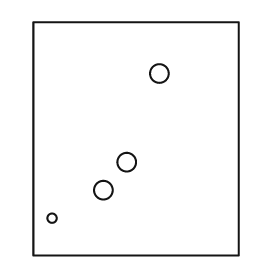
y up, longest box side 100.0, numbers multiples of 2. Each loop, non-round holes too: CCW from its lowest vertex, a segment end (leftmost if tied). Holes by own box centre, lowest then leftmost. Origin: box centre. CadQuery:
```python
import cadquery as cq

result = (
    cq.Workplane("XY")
    .moveTo(-44.0, -50.0)
    .lineTo(44.0, -50.0)
    .lineTo(44.0, 50.0)
    .lineTo(-44.0, 50.0)
    .close()
    .moveTo(-36.0, -34.0)
    .circle(2.0)
    .moveTo(-14.0, -22.0)
    .circle(4.0)
    .moveTo(-4.0, -10.0)
    .circle(4.0)
    .moveTo(10.0, 28.0)
    .circle(4.0)
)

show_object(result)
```